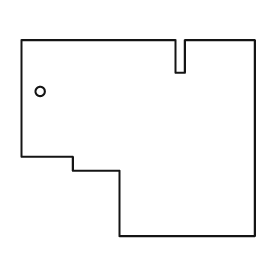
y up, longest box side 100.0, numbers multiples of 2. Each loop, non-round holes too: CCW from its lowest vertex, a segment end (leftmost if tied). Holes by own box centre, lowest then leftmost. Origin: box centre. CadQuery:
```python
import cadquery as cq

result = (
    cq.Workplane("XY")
    .moveTo(-8.0, -42.0)
    .lineTo(50.0, -42.0)
    .lineTo(50.0, 42.0)
    .lineTo(20.0, 42.0)
    .lineTo(20.0, 28.0)
    .lineTo(16.0, 28.0)
    .lineTo(16.0, 42.0)
    .lineTo(-50.0, 42.0)
    .lineTo(-50.0, -8.0)
    .lineTo(-28.0, -8.0)
    .lineTo(-28.0, -14.0)
    .lineTo(-8.0, -14.0)
    .close()
    .moveTo(-42.0, 20.0)
    .circle(2.0)
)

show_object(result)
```